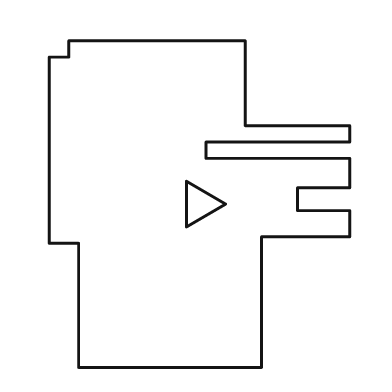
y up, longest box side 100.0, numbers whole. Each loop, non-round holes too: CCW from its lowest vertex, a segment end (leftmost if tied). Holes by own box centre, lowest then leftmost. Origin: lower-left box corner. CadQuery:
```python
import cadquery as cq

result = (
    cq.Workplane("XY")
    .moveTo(9.0, 0.0)
    .lineTo(65.0, 0.0)
    .lineTo(65.0, 40.0)
    .lineTo(92.0, 40.0)
    .lineTo(92.0, 48.0)
    .lineTo(76.0, 48.0)
    .lineTo(76.0, 55.0)
    .lineTo(92.0, 55.0)
    .lineTo(92.0, 64.0)
    .lineTo(48.0, 64.0)
    .lineTo(48.0, 69.0)
    .lineTo(92.0, 69.0)
    .lineTo(92.0, 74.0)
    .lineTo(60.0, 74.0)
    .lineTo(60.0, 100.0)
    .lineTo(6.0, 100.0)
    .lineTo(6.0, 95.0)
    .lineTo(0.0, 95.0)
    .lineTo(0.0, 38.0)
    .lineTo(9.0, 38.0)
    .close()
    .moveTo(42.0, 43.0)
    .lineTo(54.0, 50.0)
    .lineTo(42.0, 57.0)
    .close()
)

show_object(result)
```